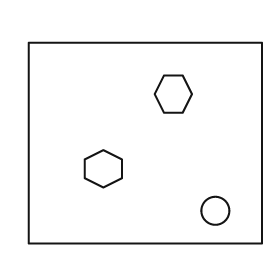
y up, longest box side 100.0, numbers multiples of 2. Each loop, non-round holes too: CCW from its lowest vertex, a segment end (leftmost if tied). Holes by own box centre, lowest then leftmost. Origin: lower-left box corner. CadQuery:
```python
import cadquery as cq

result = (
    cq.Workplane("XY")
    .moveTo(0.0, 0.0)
    .lineTo(100.0, 0.0)
    .lineTo(100.0, 86.0)
    .lineTo(0.0, 86.0)
    .close()
    .moveTo(80.0, 14.0)
    .circle(6.0)
    .moveTo(32.0, 24.0)
    .lineTo(40.0, 28.0)
    .lineTo(40.0, 36.0)
    .lineTo(32.0, 40.0)
    .lineTo(24.0, 36.0)
    .lineTo(24.0, 28.0)
    .close()
    .moveTo(58.0, 56.0)
    .lineTo(66.0, 56.0)
    .lineTo(70.0, 64.0)
    .lineTo(66.0, 72.0)
    .lineTo(58.0, 72.0)
    .lineTo(54.0, 64.0)
    .close()
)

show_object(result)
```